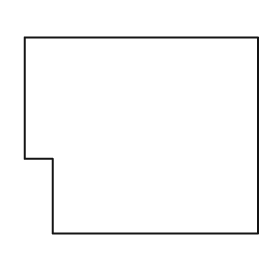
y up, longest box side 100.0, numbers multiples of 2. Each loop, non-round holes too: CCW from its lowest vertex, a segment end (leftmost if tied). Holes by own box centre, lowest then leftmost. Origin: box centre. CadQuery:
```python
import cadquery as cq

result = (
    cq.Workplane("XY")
    .moveTo(-38.0, -42.0)
    .lineTo(50.0, -42.0)
    .lineTo(50.0, 42.0)
    .lineTo(-50.0, 42.0)
    .lineTo(-50.0, -10.0)
    .lineTo(-38.0, -10.0)
    .close()
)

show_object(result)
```